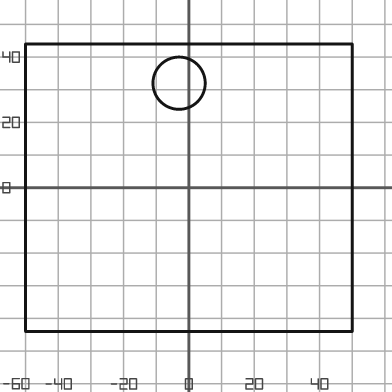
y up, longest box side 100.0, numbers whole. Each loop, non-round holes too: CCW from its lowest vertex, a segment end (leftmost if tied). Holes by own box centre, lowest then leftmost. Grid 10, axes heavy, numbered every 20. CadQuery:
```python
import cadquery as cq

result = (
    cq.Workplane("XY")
    .moveTo(-50.0, -44.0)
    .lineTo(50.0, -44.0)
    .lineTo(50.0, 44.0)
    .lineTo(-50.0, 44.0)
    .close()
    .moveTo(-3.0, 32.0)
    .circle(8.0)
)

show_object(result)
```